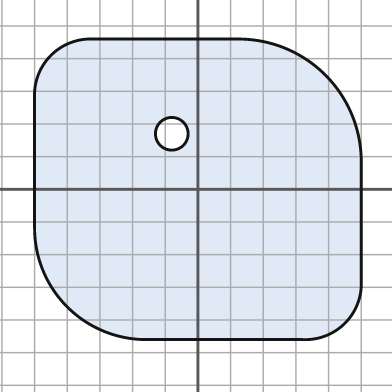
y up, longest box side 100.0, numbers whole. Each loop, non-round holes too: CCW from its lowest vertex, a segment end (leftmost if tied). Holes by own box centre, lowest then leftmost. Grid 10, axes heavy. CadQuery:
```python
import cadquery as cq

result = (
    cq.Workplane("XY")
    .moveTo(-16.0, -46.0)
    .lineTo(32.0, -46.0)
    .threePointArc((45.0, -41.0), (50.0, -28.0))
    .lineTo(50.0, 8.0)
    .threePointArc((39.0, 35.0), (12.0, 46.0))
    .lineTo(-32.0, 46.0)
    .threePointArc((-45.0, 41.0), (-50.0, 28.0))
    .lineTo(-50.0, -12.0)
    .threePointArc((-40.0, -36.0), (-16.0, -46.0))
    .close()
    .moveTo(-8.0, 17.0)
    .circle(5.0)
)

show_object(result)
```